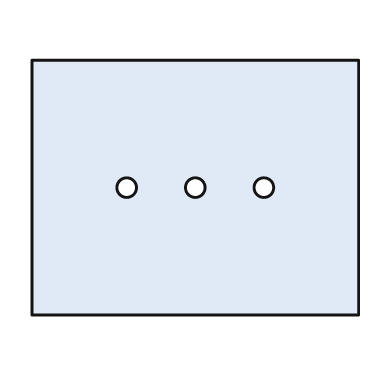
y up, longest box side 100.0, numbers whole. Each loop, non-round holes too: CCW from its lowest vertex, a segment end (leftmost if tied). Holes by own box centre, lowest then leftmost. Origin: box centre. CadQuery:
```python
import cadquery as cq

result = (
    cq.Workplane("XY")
    .moveTo(-50.0, -39.0)
    .lineTo(50.0, -39.0)
    .lineTo(50.0, 39.0)
    .lineTo(-50.0, 39.0)
    .close()
    .moveTo(-21.0, 0.0)
    .circle(3.0)
    .moveTo(0.0, 0.0)
    .circle(3.0)
    .moveTo(21.0, 0.0)
    .circle(3.0)
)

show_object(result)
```